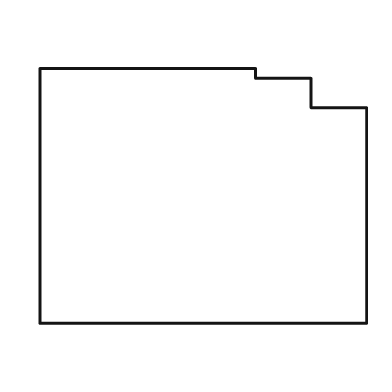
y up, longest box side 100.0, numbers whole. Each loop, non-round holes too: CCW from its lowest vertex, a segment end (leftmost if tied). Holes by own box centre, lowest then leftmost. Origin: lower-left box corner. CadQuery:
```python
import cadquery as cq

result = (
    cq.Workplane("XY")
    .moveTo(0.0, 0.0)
    .lineTo(100.0, 0.0)
    .lineTo(100.0, 66.0)
    .lineTo(83.0, 66.0)
    .lineTo(83.0, 75.0)
    .lineTo(66.0, 75.0)
    .lineTo(66.0, 78.0)
    .lineTo(0.0, 78.0)
    .close()
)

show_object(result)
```